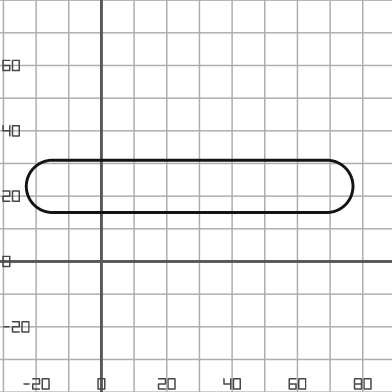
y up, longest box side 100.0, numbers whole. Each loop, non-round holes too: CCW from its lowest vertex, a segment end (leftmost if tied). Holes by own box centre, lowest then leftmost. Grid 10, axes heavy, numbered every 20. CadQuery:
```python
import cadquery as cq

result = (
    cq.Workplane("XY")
    .moveTo(-15.0, 15.0)
    .lineTo(69.0, 15.0)
    .threePointArc((77.0, 23.0), (69.0, 31.0))
    .lineTo(-15.0, 31.0)
    .threePointArc((-23.0, 23.0), (-15.0, 15.0))
    .close()
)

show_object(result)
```